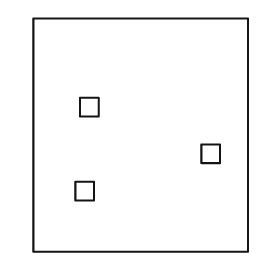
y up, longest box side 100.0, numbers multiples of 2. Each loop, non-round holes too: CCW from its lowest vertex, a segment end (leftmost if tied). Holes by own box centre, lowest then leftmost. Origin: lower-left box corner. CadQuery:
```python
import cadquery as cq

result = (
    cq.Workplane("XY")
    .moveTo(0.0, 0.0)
    .lineTo(92.0, 0.0)
    .lineTo(92.0, 100.0)
    .lineTo(0.0, 100.0)
    .close()
    .moveTo(18.0, 22.0)
    .lineTo(26.0, 22.0)
    .lineTo(26.0, 30.0)
    .lineTo(18.0, 30.0)
    .close()
    .moveTo(72.0, 38.0)
    .lineTo(80.0, 38.0)
    .lineTo(80.0, 46.0)
    .lineTo(72.0, 46.0)
    .close()
    .moveTo(20.0, 58.0)
    .lineTo(28.0, 58.0)
    .lineTo(28.0, 66.0)
    .lineTo(20.0, 66.0)
    .close()
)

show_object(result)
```